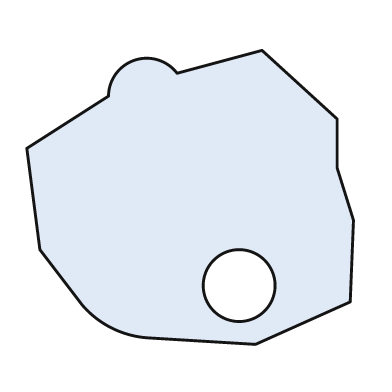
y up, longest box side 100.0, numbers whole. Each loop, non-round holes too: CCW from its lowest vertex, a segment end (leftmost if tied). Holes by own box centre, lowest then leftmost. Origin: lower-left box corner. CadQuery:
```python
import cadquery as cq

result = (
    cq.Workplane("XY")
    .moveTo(70.0, 0.0)
    .lineTo(99.0, 13.0)
    .lineTo(100.0, 38.0)
    .lineTo(95.0, 54.0)
    .lineTo(95.0, 69.0)
    .lineTo(72.0, 90.0)
    .lineTo(46.0, 83.0)
    .threePointArc((33.0, 87.0), (25.0, 76.0))
    .lineTo(0.0, 60.0)
    .lineTo(4.0, 29.0)
    .lineTo(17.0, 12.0)
    .threePointArc((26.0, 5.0), (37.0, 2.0))
    .close()
    .moveTo(65.0, 18.0)
    .circle(11.0)
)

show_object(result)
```